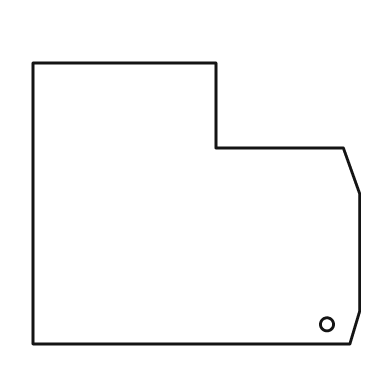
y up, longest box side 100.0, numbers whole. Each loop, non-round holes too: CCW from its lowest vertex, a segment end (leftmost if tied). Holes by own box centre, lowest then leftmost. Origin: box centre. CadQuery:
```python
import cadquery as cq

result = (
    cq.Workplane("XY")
    .moveTo(-50.0, -43.0)
    .lineTo(47.0, -43.0)
    .lineTo(50.0, -33.0)
    .lineTo(50.0, 3.0)
    .lineTo(45.0, 17.0)
    .lineTo(6.0, 17.0)
    .lineTo(6.0, 43.0)
    .lineTo(-50.0, 43.0)
    .close()
    .moveTo(40.0, -37.0)
    .circle(2.0)
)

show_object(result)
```